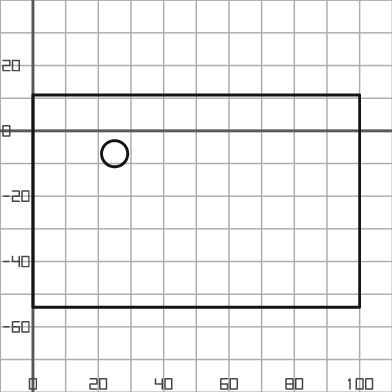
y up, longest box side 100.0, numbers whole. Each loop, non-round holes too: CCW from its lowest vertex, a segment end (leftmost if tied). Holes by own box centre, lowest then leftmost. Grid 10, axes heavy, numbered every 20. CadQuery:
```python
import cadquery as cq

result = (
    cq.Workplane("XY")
    .moveTo(0.0, -54.0)
    .lineTo(100.0, -54.0)
    .lineTo(100.0, 11.0)
    .lineTo(0.0, 11.0)
    .close()
    .moveTo(25.0, -7.0)
    .circle(4.0)
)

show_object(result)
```